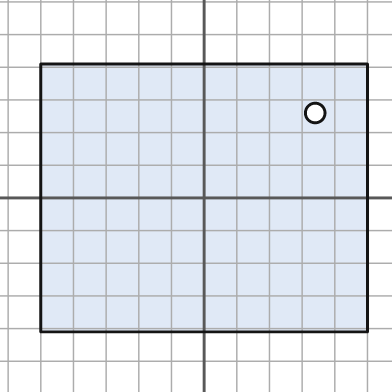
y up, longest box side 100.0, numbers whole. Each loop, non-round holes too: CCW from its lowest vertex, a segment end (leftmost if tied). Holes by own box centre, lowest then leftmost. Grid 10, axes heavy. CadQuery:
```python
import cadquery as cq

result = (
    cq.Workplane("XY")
    .moveTo(-50.0, -41.0)
    .lineTo(50.0, -41.0)
    .lineTo(50.0, 41.0)
    .lineTo(-50.0, 41.0)
    .close()
    .moveTo(34.0, 26.0)
    .circle(3.0)
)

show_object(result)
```